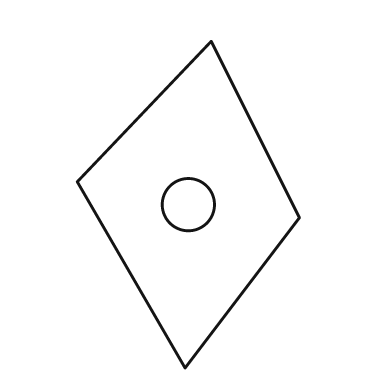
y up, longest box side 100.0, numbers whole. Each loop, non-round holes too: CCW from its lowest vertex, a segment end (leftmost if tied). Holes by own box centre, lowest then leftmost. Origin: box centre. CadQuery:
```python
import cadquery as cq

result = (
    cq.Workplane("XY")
    .moveTo(-1.0, -50.0)
    .lineTo(34.0, -4.0)
    .lineTo(7.0, 50.0)
    .lineTo(-34.0, 7.0)
    .close()
    .moveTo(0.0, 0.0)
    .circle(8.0)
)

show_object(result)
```